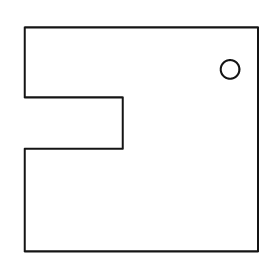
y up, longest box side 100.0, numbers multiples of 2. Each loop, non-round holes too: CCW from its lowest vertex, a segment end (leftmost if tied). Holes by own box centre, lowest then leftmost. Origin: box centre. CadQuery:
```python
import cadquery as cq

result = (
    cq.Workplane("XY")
    .moveTo(-50.0, -48.0)
    .lineTo(50.0, -48.0)
    .lineTo(50.0, 48.0)
    .lineTo(-50.0, 48.0)
    .lineTo(-50.0, 18.0)
    .lineTo(-8.0, 18.0)
    .lineTo(-8.0, -4.0)
    .lineTo(-50.0, -4.0)
    .close()
    .moveTo(38.0, 30.0)
    .circle(4.0)
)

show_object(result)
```